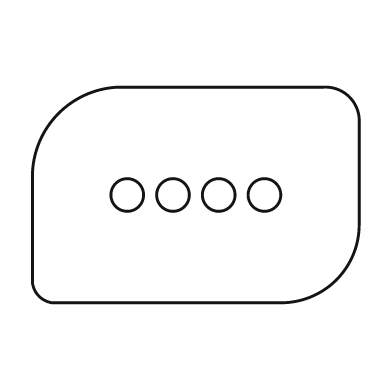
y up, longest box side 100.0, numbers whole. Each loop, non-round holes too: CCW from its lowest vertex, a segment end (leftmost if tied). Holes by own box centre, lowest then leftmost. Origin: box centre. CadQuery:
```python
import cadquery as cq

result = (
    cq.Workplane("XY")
    .moveTo(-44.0, -33.0)
    .lineTo(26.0, -33.0)
    .threePointArc((43.0, -26.0), (50.0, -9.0))
    .lineTo(50.0, 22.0)
    .threePointArc((47.0, 30.0), (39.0, 33.0))
    .lineTo(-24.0, 33.0)
    .threePointArc((-42.0, 25.0), (-50.0, 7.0))
    .lineTo(-50.0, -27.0)
    .threePointArc((-48.0, -31.0), (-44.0, -33.0))
    .close()
    .moveTo(-21.0, 0.0)
    .circle(5.0)
    .moveTo(-7.0, 0.0)
    .circle(5.0)
    .moveTo(7.0, 0.0)
    .circle(5.0)
    .moveTo(21.0, 0.0)
    .circle(5.0)
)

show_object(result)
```